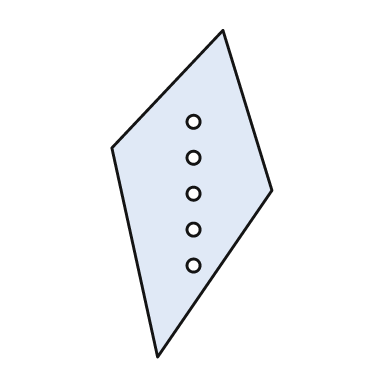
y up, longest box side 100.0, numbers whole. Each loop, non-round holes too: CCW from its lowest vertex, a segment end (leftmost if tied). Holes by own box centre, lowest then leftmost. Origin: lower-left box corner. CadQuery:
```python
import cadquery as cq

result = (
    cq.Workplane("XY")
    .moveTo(14.0, 0.0)
    .lineTo(49.0, 51.0)
    .lineTo(34.0, 100.0)
    .lineTo(0.0, 64.0)
    .close()
    .moveTo(25.0, 28.0)
    .circle(2.0)
    .moveTo(25.0, 39.0)
    .circle(2.0)
    .moveTo(25.0, 50.0)
    .circle(2.0)
    .moveTo(25.0, 61.0)
    .circle(2.0)
    .moveTo(25.0, 72.0)
    .circle(2.0)
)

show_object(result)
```